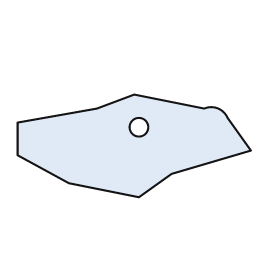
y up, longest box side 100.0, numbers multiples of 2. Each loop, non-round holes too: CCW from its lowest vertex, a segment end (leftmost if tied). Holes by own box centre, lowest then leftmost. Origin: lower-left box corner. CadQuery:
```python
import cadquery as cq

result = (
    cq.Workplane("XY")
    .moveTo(52.0, 0.0)
    .lineTo(66.0, 10.0)
    .lineTo(100.0, 20.0)
    .lineTo(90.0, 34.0)
    .threePointArc((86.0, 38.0), (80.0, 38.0))
    .lineTo(50.0, 44.0)
    .lineTo(34.0, 38.0)
    .lineTo(0.0, 32.0)
    .lineTo(0.0, 18.0)
    .lineTo(22.0, 6.0)
    .close()
    .moveTo(52.0, 30.0)
    .circle(4.0)
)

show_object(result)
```